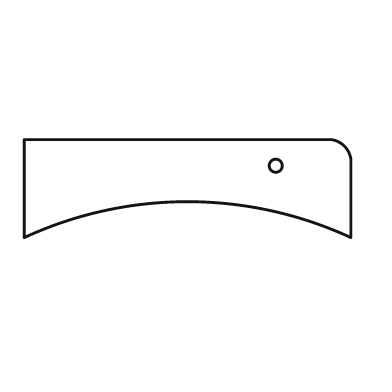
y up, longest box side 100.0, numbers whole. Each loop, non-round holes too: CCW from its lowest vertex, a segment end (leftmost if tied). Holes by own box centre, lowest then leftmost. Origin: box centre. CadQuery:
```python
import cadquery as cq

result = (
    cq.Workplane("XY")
    .moveTo(-50.0, -15.0)
    .threePointArc((0.0, -4.0), (50.0, -15.0))
    .lineTo(50.0, 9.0)
    .threePointArc((48.0, 13.0), (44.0, 15.0))
    .lineTo(-50.0, 15.0)
    .close()
    .moveTo(27.0, 7.0)
    .circle(2.0)
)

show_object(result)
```